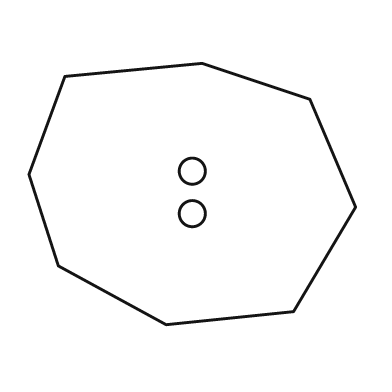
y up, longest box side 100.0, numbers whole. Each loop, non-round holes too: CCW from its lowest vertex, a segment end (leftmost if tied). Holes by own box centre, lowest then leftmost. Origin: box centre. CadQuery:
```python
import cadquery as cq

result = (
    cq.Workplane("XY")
    .moveTo(-8.0, -40.0)
    .lineTo(31.0, -36.0)
    .lineTo(50.0, -4.0)
    .lineTo(36.0, 29.0)
    .lineTo(3.0, 40.0)
    .lineTo(-39.0, 36.0)
    .lineTo(-50.0, 6.0)
    .lineTo(-41.0, -22.0)
    .close()
    .moveTo(0.0, -6.0)
    .circle(4.0)
    .moveTo(0.0, 7.0)
    .circle(4.0)
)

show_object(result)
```